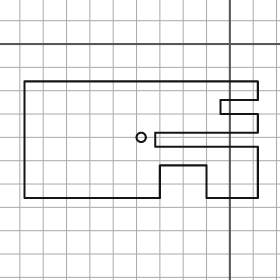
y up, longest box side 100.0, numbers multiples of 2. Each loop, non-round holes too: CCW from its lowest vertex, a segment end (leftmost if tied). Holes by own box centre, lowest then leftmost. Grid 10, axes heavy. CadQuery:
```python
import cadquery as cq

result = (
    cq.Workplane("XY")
    .moveTo(-88.0, -66.0)
    .lineTo(-30.0, -66.0)
    .lineTo(-30.0, -52.0)
    .lineTo(-10.0, -52.0)
    .lineTo(-10.0, -66.0)
    .lineTo(12.0, -66.0)
    .lineTo(12.0, -44.0)
    .lineTo(-32.0, -44.0)
    .lineTo(-32.0, -38.0)
    .lineTo(12.0, -38.0)
    .lineTo(12.0, -30.0)
    .lineTo(-4.0, -30.0)
    .lineTo(-4.0, -24.0)
    .lineTo(12.0, -24.0)
    .lineTo(12.0, -16.0)
    .lineTo(-88.0, -16.0)
    .close()
    .moveTo(-38.0, -40.0)
    .circle(2.0)
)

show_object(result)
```